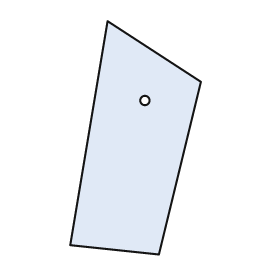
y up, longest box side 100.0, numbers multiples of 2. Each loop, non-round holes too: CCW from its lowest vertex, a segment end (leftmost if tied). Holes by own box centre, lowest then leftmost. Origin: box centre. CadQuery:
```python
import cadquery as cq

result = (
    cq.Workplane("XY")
    .moveTo(10.0, -50.0)
    .lineTo(28.0, 24.0)
    .lineTo(-12.0, 50.0)
    .lineTo(-28.0, -46.0)
    .close()
    .moveTo(4.0, 16.0)
    .circle(2.0)
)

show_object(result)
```